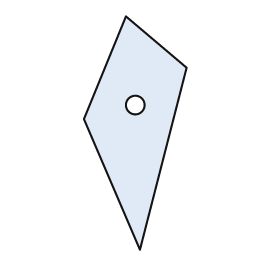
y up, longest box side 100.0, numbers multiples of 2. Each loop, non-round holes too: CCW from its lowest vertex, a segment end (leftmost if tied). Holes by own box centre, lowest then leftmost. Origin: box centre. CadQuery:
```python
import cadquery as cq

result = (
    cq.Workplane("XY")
    .moveTo(2.0, -50.0)
    .lineTo(22.0, 28.0)
    .lineTo(-4.0, 50.0)
    .lineTo(-22.0, 6.0)
    .close()
    .moveTo(0.0, 12.0)
    .circle(4.0)
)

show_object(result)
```